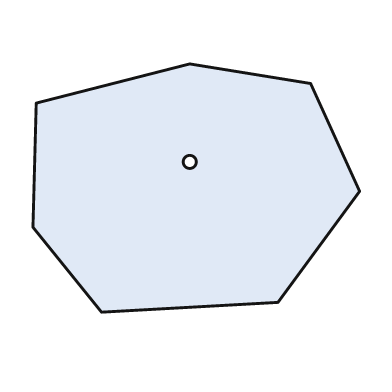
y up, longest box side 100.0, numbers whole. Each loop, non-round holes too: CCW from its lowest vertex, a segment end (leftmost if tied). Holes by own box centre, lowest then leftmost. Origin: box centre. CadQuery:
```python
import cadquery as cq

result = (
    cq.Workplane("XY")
    .moveTo(-29.0, -38.0)
    .lineTo(25.0, -35.0)
    .lineTo(50.0, -1.0)
    .lineTo(35.0, 32.0)
    .lineTo(-2.0, 38.0)
    .lineTo(-49.0, 26.0)
    .lineTo(-50.0, -12.0)
    .close()
    .moveTo(-2.0, 8.0)
    .circle(2.0)
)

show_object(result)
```